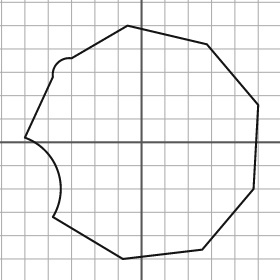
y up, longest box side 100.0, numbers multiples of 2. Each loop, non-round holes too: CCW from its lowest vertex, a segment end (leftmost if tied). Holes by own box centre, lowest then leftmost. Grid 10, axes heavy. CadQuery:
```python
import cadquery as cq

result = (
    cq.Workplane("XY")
    .moveTo(-8.0, -50.0)
    .lineTo(26.0, -46.0)
    .lineTo(48.0, -20.0)
    .lineTo(50.0, 16.0)
    .lineTo(28.0, 42.0)
    .lineTo(-6.0, 50.0)
    .lineTo(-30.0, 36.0)
    .threePointArc((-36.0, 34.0), (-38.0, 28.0))
    .lineTo(-50.0, 2.0)
    .threePointArc((-36.0, -12.0), (-38.0, -32.0))
    .close()
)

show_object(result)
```